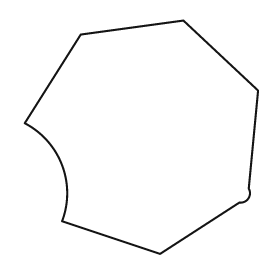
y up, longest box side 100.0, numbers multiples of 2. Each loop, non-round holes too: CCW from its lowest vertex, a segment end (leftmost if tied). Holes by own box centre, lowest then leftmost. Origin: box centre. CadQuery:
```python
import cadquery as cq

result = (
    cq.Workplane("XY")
    .moveTo(8.0, -50.0)
    .lineTo(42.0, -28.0)
    .threePointArc((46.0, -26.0), (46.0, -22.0))
    .lineTo(50.0, 20.0)
    .lineTo(18.0, 50.0)
    .lineTo(-26.0, 44.0)
    .lineTo(-50.0, 6.0)
    .threePointArc((-34.0, -12.0), (-34.0, -36.0))
    .close()
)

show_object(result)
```